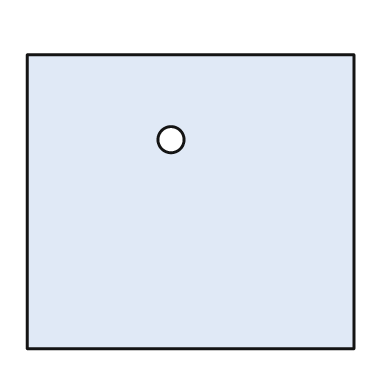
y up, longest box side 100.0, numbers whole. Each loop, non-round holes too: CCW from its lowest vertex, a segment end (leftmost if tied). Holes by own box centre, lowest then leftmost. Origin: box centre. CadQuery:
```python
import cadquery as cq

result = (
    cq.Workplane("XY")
    .moveTo(-50.0, -45.0)
    .lineTo(50.0, -45.0)
    .lineTo(50.0, 45.0)
    .lineTo(-50.0, 45.0)
    .close()
    .moveTo(-6.0, 19.0)
    .circle(4.0)
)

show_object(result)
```